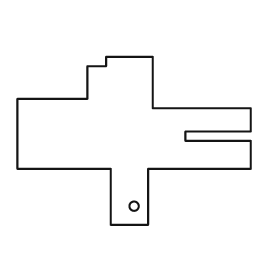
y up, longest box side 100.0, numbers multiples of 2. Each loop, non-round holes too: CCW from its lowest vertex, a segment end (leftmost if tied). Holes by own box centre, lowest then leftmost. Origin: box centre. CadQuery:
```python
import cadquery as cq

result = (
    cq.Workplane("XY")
    .moveTo(-10.0, -36.0)
    .lineTo(6.0, -36.0)
    .lineTo(6.0, -12.0)
    .lineTo(50.0, -12.0)
    .lineTo(50.0, 0.0)
    .lineTo(22.0, 0.0)
    .lineTo(22.0, 4.0)
    .lineTo(50.0, 4.0)
    .lineTo(50.0, 14.0)
    .lineTo(8.0, 14.0)
    .lineTo(8.0, 36.0)
    .lineTo(-12.0, 36.0)
    .lineTo(-12.0, 32.0)
    .lineTo(-20.0, 32.0)
    .lineTo(-20.0, 18.0)
    .lineTo(-50.0, 18.0)
    .lineTo(-50.0, -12.0)
    .lineTo(-10.0, -12.0)
    .close()
    .moveTo(0.0, -28.0)
    .circle(2.0)
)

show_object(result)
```